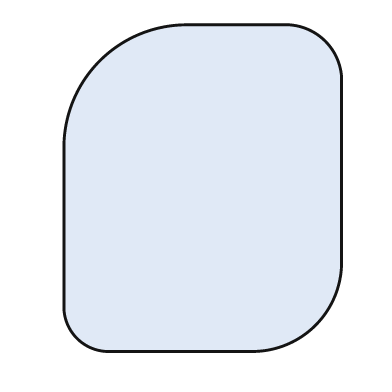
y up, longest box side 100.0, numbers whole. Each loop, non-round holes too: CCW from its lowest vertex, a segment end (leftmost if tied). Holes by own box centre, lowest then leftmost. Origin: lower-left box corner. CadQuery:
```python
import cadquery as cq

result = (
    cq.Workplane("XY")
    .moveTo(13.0, 0.0)
    .lineTo(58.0, 0.0)
    .threePointArc((77.0, 8.0), (85.0, 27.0))
    .lineTo(85.0, 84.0)
    .threePointArc((80.0, 95.0), (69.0, 100.0))
    .lineTo(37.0, 100.0)
    .threePointArc((11.0, 89.0), (0.0, 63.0))
    .lineTo(0.0, 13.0)
    .threePointArc((4.0, 4.0), (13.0, 0.0))
    .close()
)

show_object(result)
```